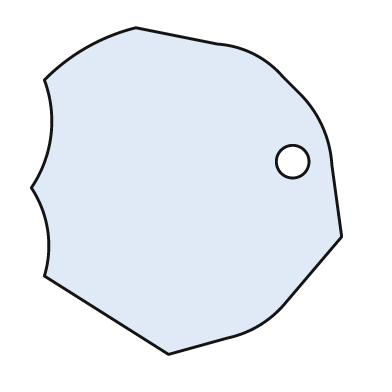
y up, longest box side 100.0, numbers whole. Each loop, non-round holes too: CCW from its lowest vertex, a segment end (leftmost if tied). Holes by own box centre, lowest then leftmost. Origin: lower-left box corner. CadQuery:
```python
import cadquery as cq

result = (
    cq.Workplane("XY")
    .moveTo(42.0, 0.0)
    .lineTo(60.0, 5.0)
    .threePointArc((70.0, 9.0), (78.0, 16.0))
    .lineTo(95.0, 36.0)
    .lineTo(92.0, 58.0)
    .threePointArc((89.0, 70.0), (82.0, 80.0))
    .lineTo(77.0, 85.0)
    .threePointArc((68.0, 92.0), (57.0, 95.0))
    .lineTo(32.0, 100.0)
    .threePointArc((17.0, 94.0), (4.0, 84.0))
    .threePointArc((6.0, 67.0), (0.0, 51.0))
    .threePointArc((5.0, 38.0), (4.0, 24.0))
    .close()
    .moveTo(80.0, 59.0)
    .circle(5.0)
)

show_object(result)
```